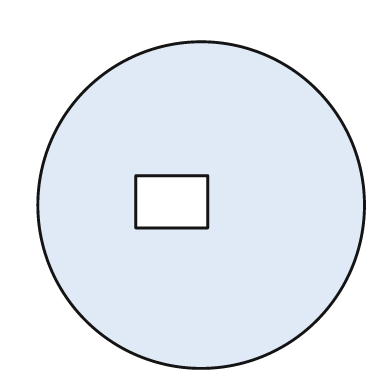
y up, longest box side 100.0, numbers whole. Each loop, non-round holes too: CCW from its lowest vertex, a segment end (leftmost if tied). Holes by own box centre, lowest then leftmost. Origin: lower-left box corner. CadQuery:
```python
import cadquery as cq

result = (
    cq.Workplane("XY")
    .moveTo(50.0, 50.0)
    .circle(50.0)
    .moveTo(30.0, 43.0)
    .lineTo(52.0, 43.0)
    .lineTo(52.0, 59.0)
    .lineTo(30.0, 59.0)
    .close()
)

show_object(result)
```